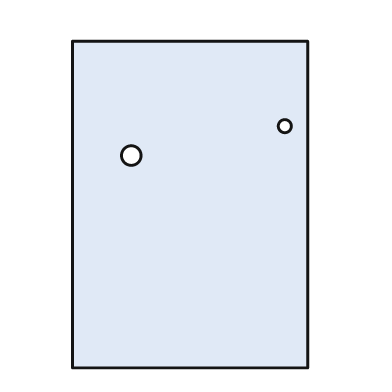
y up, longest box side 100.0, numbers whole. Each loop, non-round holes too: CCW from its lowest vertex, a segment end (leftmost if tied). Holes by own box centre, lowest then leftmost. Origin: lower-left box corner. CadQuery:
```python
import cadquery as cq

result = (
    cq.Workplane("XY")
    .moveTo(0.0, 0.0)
    .lineTo(72.0, 0.0)
    .lineTo(72.0, 100.0)
    .lineTo(0.0, 100.0)
    .close()
    .moveTo(18.0, 65.0)
    .circle(3.0)
    .moveTo(65.0, 74.0)
    .circle(2.0)
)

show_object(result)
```